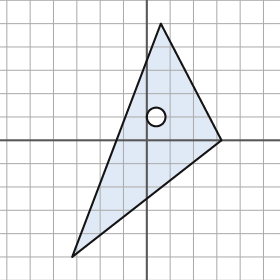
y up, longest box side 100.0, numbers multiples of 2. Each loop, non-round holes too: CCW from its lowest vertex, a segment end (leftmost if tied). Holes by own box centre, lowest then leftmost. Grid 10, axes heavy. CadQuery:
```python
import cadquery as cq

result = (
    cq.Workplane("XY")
    .moveTo(-32.0, -50.0)
    .lineTo(32.0, 0.0)
    .lineTo(6.0, 50.0)
    .close()
    .moveTo(4.0, 10.0)
    .circle(4.0)
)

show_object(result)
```